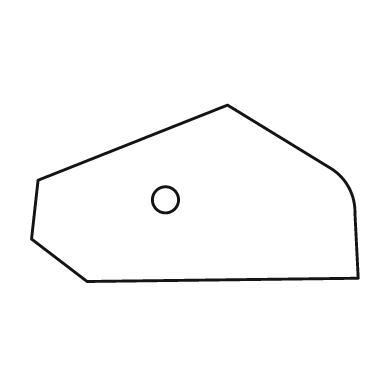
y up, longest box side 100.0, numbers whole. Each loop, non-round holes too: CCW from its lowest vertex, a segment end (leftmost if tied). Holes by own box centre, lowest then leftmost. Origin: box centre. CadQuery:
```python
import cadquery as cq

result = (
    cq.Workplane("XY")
    .moveTo(-33.0, -27.0)
    .lineTo(50.0, -26.0)
    .lineTo(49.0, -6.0)
    .threePointArc((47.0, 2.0), (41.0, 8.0))
    .lineTo(10.0, 27.0)
    .lineTo(-48.0, 4.0)
    .lineTo(-50.0, -14.0)
    .close()
    .moveTo(-9.0, -2.0)
    .circle(4.0)
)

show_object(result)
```